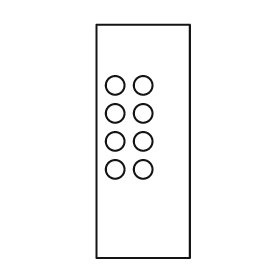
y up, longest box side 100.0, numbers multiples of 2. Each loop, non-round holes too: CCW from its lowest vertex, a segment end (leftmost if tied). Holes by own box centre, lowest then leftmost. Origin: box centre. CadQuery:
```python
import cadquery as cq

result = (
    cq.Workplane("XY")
    .moveTo(-20.0, -50.0)
    .lineTo(20.0, -50.0)
    .lineTo(20.0, 50.0)
    .lineTo(-20.0, 50.0)
    .close()
    .moveTo(-12.0, -12.0)
    .circle(4.0)
    .moveTo(0.0, -12.0)
    .circle(4.0)
    .moveTo(-12.0, 0.0)
    .circle(4.0)
    .moveTo(0.0, 0.0)
    .circle(4.0)
    .moveTo(-12.0, 12.0)
    .circle(4.0)
    .moveTo(0.0, 12.0)
    .circle(4.0)
    .moveTo(-12.0, 24.0)
    .circle(4.0)
    .moveTo(0.0, 24.0)
    .circle(4.0)
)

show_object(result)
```